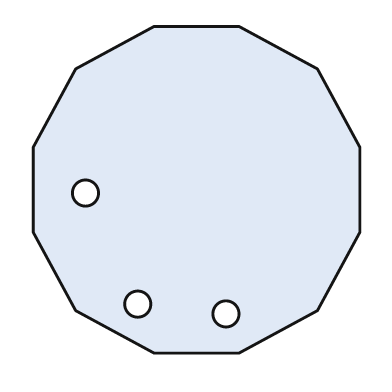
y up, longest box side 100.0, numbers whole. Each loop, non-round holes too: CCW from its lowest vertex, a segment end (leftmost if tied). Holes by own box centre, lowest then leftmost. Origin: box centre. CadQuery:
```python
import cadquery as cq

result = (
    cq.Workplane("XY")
    .moveTo(-13.0, -50.0)
    .lineTo(13.0, -50.0)
    .lineTo(37.0, -37.0)
    .lineTo(50.0, -13.0)
    .lineTo(50.0, 13.0)
    .lineTo(37.0, 37.0)
    .lineTo(13.0, 50.0)
    .lineTo(-13.0, 50.0)
    .lineTo(-37.0, 37.0)
    .lineTo(-50.0, 13.0)
    .lineTo(-50.0, -13.0)
    .lineTo(-37.0, -37.0)
    .close()
    .moveTo(9.0, -38.0)
    .circle(4.0)
    .moveTo(-18.0, -35.0)
    .circle(4.0)
    .moveTo(-34.0, -1.0)
    .circle(4.0)
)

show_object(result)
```